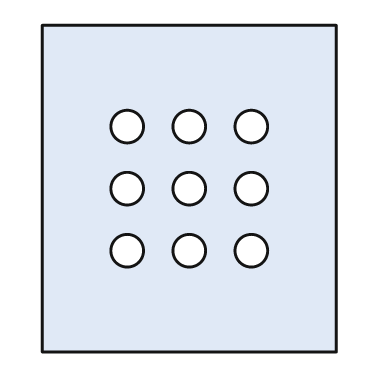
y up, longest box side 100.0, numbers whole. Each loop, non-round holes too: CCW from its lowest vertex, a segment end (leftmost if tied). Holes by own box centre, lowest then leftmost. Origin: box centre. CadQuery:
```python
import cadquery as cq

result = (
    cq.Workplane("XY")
    .moveTo(-45.0, -50.0)
    .lineTo(45.0, -50.0)
    .lineTo(45.0, 50.0)
    .lineTo(-45.0, 50.0)
    .close()
    .moveTo(-19.0, -19.0)
    .circle(5.0)
    .moveTo(0.0, -19.0)
    .circle(5.0)
    .moveTo(19.0, -19.0)
    .circle(5.0)
    .moveTo(-19.0, 0.0)
    .circle(5.0)
    .moveTo(0.0, 0.0)
    .circle(5.0)
    .moveTo(19.0, 0.0)
    .circle(5.0)
    .moveTo(-19.0, 19.0)
    .circle(5.0)
    .moveTo(0.0, 19.0)
    .circle(5.0)
    .moveTo(19.0, 19.0)
    .circle(5.0)
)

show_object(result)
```